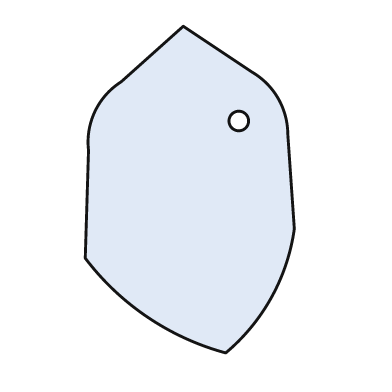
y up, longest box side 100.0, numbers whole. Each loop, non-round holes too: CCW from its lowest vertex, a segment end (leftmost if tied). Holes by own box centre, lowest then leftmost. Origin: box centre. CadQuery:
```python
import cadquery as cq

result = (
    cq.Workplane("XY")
    .moveTo(11.0, -50.0)
    .threePointArc((25.0, -33.0), (32.0, -12.0))
    .lineTo(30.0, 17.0)
    .threePointArc((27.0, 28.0), (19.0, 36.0))
    .lineTo(-2.0, 50.0)
    .lineTo(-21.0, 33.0)
    .threePointArc((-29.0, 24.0), (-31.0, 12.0))
    .lineTo(-32.0, -21.0)
    .threePointArc((-13.0, -39.0), (11.0, -50.0))
    .close()
    .moveTo(15.0, 21.0)
    .circle(3.0)
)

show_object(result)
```